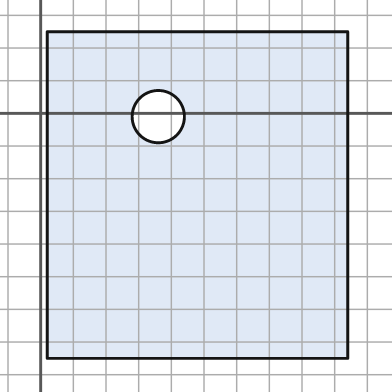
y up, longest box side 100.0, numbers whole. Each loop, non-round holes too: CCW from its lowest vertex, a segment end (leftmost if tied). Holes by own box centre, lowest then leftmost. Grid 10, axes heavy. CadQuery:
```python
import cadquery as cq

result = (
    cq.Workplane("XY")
    .moveTo(2.0, -75.0)
    .lineTo(94.0, -75.0)
    .lineTo(94.0, 25.0)
    .lineTo(2.0, 25.0)
    .close()
    .moveTo(36.0, -1.0)
    .circle(8.0)
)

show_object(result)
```